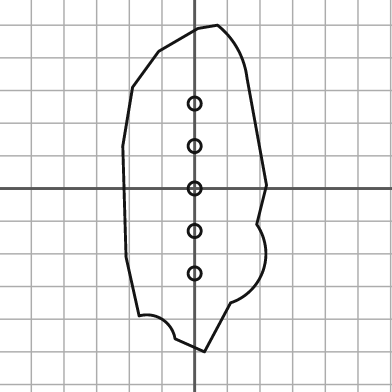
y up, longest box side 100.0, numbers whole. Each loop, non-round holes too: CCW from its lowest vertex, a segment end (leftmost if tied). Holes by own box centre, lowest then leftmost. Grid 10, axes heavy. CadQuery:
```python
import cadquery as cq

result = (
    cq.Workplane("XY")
    .moveTo(3.0, -50.0)
    .lineTo(11.0, -35.0)
    .threePointArc((21.0, -25.0), (19.0, -11.0))
    .lineTo(22.0, 1.0)
    .lineTo(16.0, 34.0)
    .threePointArc((13.0, 43.0), (7.0, 50.0))
    .lineTo(1.0, 49.0)
    .lineTo(-11.0, 42.0)
    .lineTo(-19.0, 31.0)
    .lineTo(-22.0, 13.0)
    .lineTo(-21.0, -21.0)
    .lineTo(-17.0, -39.0)
    .threePointArc((-10.0, -40.0), (-6.0, -46.0))
    .close()
    .moveTo(0.0, -26.0)
    .circle(2.0)
    .moveTo(0.0, -13.0)
    .circle(2.0)
    .moveTo(0.0, 0.0)
    .circle(2.0)
    .moveTo(0.0, 13.0)
    .circle(2.0)
    .moveTo(0.0, 26.0)
    .circle(2.0)
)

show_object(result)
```